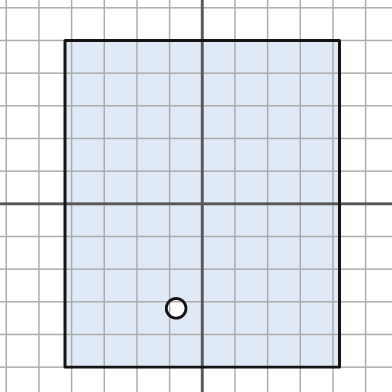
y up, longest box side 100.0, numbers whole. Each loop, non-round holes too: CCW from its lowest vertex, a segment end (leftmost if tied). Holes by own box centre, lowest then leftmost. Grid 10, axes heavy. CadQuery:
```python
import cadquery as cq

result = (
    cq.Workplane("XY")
    .moveTo(-42.0, -50.0)
    .lineTo(42.0, -50.0)
    .lineTo(42.0, 50.0)
    .lineTo(-42.0, 50.0)
    .close()
    .moveTo(-8.0, -32.0)
    .circle(3.0)
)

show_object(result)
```